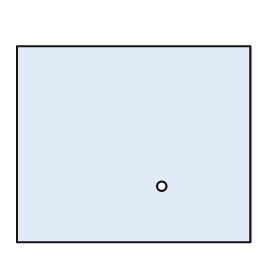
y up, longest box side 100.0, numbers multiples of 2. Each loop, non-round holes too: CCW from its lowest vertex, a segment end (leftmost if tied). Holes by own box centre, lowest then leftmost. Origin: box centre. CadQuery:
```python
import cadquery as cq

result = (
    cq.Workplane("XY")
    .moveTo(-50.0, -42.0)
    .lineTo(50.0, -42.0)
    .lineTo(50.0, 42.0)
    .lineTo(-50.0, 42.0)
    .close()
    .moveTo(12.0, -18.0)
    .circle(2.0)
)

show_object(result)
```